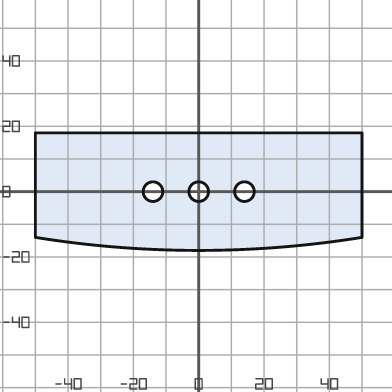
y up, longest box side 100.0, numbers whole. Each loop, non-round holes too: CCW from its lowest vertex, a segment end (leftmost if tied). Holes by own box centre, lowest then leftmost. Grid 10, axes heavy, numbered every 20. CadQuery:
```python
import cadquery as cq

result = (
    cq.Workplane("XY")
    .moveTo(-50.0, -14.0)
    .threePointArc((0.0, -18.0), (50.0, -14.0))
    .lineTo(50.0, 18.0)
    .lineTo(-50.0, 18.0)
    .close()
    .moveTo(-14.0, 0.0)
    .circle(3.0)
    .moveTo(0.0, 0.0)
    .circle(3.0)
    .moveTo(14.0, 0.0)
    .circle(3.0)
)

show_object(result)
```